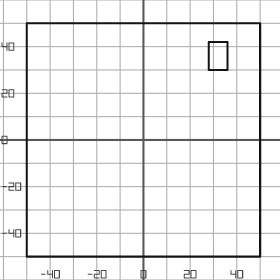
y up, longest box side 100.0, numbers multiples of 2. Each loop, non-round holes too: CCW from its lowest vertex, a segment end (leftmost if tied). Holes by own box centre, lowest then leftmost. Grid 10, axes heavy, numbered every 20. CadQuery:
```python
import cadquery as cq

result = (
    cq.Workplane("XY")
    .moveTo(-50.0, -50.0)
    .lineTo(50.0, -50.0)
    .lineTo(50.0, 50.0)
    .lineTo(-50.0, 50.0)
    .close()
    .moveTo(28.0, 30.0)
    .lineTo(36.0, 30.0)
    .lineTo(36.0, 42.0)
    .lineTo(28.0, 42.0)
    .close()
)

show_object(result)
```